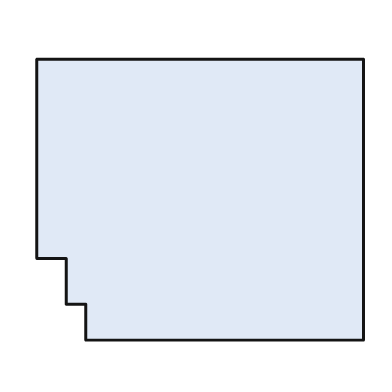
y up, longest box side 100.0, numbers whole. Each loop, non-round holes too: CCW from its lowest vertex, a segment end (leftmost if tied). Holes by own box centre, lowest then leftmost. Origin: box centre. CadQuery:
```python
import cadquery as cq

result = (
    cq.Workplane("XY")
    .moveTo(-35.0, -43.0)
    .lineTo(50.0, -43.0)
    .lineTo(50.0, 43.0)
    .lineTo(-50.0, 43.0)
    .lineTo(-50.0, -18.0)
    .lineTo(-41.0, -18.0)
    .lineTo(-41.0, -32.0)
    .lineTo(-35.0, -32.0)
    .close()
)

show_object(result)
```